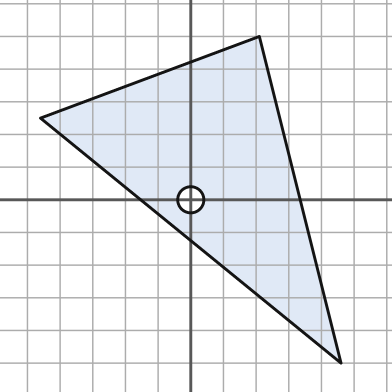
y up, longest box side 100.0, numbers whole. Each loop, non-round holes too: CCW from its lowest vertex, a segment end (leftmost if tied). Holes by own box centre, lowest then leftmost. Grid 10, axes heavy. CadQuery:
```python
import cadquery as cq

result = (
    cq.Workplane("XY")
    .moveTo(46.0, -50.0)
    .lineTo(21.0, 50.0)
    .lineTo(-46.0, 25.0)
    .close()
    .moveTo(0.0, 0.0)
    .circle(4.0)
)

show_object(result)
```